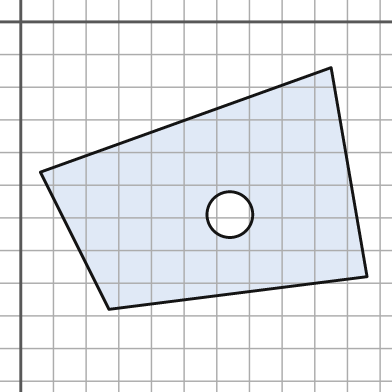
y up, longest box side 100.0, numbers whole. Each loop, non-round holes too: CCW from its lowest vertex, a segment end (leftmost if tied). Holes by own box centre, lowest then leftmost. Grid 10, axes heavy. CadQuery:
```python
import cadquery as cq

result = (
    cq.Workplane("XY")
    .moveTo(27.0, -88.0)
    .lineTo(106.0, -78.0)
    .lineTo(95.0, -14.0)
    .lineTo(6.0, -46.0)
    .close()
    .moveTo(64.0, -59.0)
    .circle(7.0)
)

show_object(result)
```